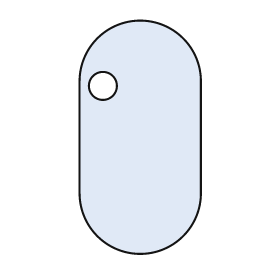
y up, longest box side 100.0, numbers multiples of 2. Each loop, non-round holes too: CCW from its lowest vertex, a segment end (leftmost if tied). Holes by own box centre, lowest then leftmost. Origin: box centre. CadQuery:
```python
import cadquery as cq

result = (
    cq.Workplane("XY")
    .moveTo(-26.0, -24.0)
    .threePointArc((0.0, -50.0), (26.0, -24.0))
    .lineTo(26.0, 24.0)
    .threePointArc((0.0, 50.0), (-26.0, 24.0))
    .close()
    .moveTo(-16.0, 22.0)
    .circle(6.0)
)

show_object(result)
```